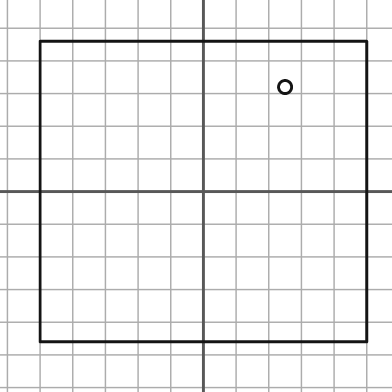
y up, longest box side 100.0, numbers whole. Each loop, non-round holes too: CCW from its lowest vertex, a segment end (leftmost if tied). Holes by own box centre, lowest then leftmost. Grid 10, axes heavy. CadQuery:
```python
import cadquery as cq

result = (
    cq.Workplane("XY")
    .moveTo(-50.0, -46.0)
    .lineTo(50.0, -46.0)
    .lineTo(50.0, 46.0)
    .lineTo(-50.0, 46.0)
    .close()
    .moveTo(25.0, 32.0)
    .circle(2.0)
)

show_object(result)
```